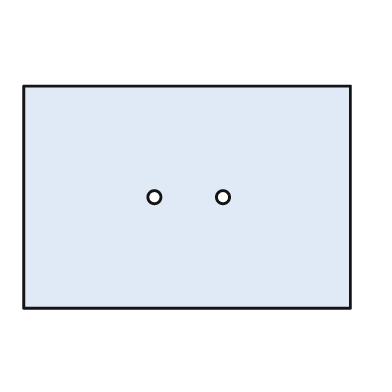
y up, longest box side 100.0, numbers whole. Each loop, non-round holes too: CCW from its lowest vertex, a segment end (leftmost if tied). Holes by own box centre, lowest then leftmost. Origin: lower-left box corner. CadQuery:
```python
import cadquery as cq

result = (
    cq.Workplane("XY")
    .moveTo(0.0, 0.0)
    .lineTo(100.0, 0.0)
    .lineTo(100.0, 68.0)
    .lineTo(0.0, 68.0)
    .close()
    .moveTo(40.0, 34.0)
    .circle(2.0)
    .moveTo(61.0, 34.0)
    .circle(2.0)
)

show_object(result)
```